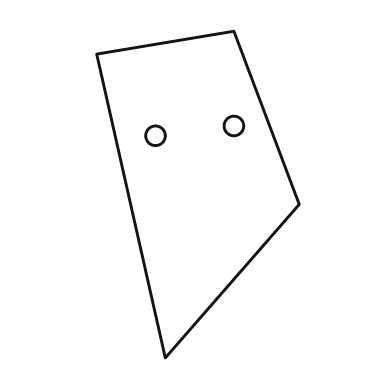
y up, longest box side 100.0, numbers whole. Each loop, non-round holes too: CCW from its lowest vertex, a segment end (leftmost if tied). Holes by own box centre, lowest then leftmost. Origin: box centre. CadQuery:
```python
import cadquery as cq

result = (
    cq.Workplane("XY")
    .moveTo(-10.0, -50.0)
    .lineTo(31.0, -3.0)
    .lineTo(11.0, 50.0)
    .lineTo(-31.0, 43.0)
    .close()
    .moveTo(-13.0, 18.0)
    .circle(3.0)
    .moveTo(11.0, 21.0)
    .circle(3.0)
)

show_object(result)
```